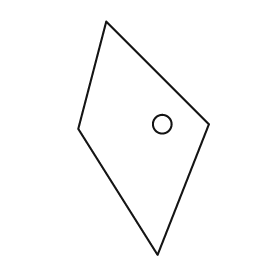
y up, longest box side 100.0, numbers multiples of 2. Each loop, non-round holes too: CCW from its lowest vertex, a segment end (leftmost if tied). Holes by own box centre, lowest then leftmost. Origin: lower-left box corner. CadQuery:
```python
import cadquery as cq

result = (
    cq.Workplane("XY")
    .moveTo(34.0, 0.0)
    .lineTo(56.0, 56.0)
    .lineTo(12.0, 100.0)
    .lineTo(0.0, 54.0)
    .close()
    .moveTo(36.0, 56.0)
    .circle(4.0)
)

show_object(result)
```